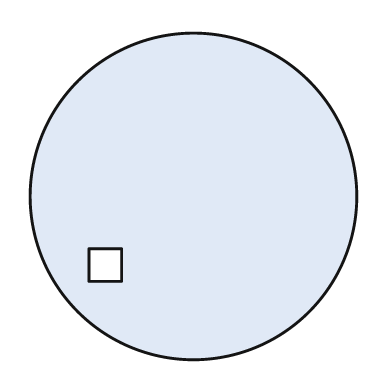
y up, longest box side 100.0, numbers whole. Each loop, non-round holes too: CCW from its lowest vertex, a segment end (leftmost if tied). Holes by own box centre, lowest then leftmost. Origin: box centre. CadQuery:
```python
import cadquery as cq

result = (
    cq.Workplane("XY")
    .moveTo(0.0, 0.0)
    .circle(50.0)
    .moveTo(-32.0, -26.0)
    .lineTo(-22.0, -26.0)
    .lineTo(-22.0, -16.0)
    .lineTo(-32.0, -16.0)
    .close()
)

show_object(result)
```